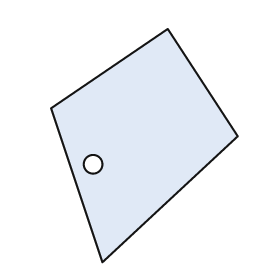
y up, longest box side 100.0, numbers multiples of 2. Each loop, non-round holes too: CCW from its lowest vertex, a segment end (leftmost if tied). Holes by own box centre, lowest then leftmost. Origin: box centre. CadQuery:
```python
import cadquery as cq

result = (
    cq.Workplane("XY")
    .moveTo(-18.0, -50.0)
    .lineTo(40.0, 4.0)
    .lineTo(10.0, 50.0)
    .lineTo(-40.0, 16.0)
    .close()
    .moveTo(-22.0, -8.0)
    .circle(4.0)
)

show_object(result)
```